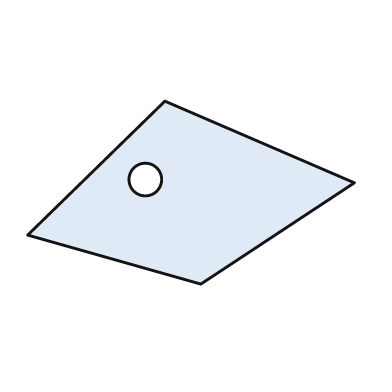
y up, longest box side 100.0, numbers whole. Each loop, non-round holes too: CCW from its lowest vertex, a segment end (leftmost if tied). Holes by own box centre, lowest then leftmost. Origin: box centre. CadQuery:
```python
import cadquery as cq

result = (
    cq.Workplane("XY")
    .moveTo(3.0, -28.0)
    .lineTo(50.0, 3.0)
    .lineTo(-8.0, 28.0)
    .lineTo(-50.0, -13.0)
    .close()
    .moveTo(-14.0, 4.0)
    .circle(5.0)
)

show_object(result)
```